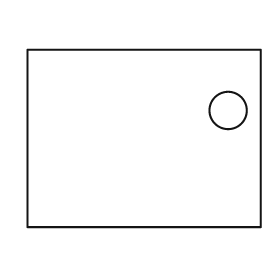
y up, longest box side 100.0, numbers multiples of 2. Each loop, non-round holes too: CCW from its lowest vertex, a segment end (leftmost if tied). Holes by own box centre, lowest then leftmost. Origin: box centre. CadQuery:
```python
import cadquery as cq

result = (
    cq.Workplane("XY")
    .moveTo(-50.0, -38.0)
    .lineTo(50.0, -38.0)
    .lineTo(50.0, 38.0)
    .lineTo(-50.0, 38.0)
    .close()
    .moveTo(36.0, 12.0)
    .circle(8.0)
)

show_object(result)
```